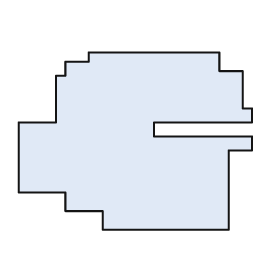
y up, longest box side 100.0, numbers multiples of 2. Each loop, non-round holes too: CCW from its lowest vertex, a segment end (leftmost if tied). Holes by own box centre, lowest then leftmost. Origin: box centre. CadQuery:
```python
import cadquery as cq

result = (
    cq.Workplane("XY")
    .moveTo(-14.0, -38.0)
    .lineTo(40.0, -38.0)
    .lineTo(40.0, -4.0)
    .lineTo(50.0, -4.0)
    .lineTo(50.0, 2.0)
    .lineTo(8.0, 2.0)
    .lineTo(8.0, 8.0)
    .lineTo(50.0, 8.0)
    .lineTo(50.0, 14.0)
    .lineTo(46.0, 14.0)
    .lineTo(46.0, 30.0)
    .lineTo(36.0, 30.0)
    .lineTo(36.0, 38.0)
    .lineTo(-20.0, 38.0)
    .lineTo(-20.0, 34.0)
    .lineTo(-30.0, 34.0)
    .lineTo(-30.0, 28.0)
    .lineTo(-34.0, 28.0)
    .lineTo(-34.0, 8.0)
    .lineTo(-50.0, 8.0)
    .lineTo(-50.0, -22.0)
    .lineTo(-30.0, -22.0)
    .lineTo(-30.0, -30.0)
    .lineTo(-14.0, -30.0)
    .close()
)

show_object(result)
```